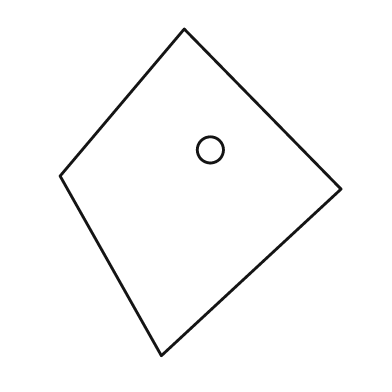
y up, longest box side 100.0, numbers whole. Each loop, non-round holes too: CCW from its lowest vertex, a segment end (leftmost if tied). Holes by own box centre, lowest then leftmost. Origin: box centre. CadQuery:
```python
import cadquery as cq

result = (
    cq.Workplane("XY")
    .moveTo(-12.0, -50.0)
    .lineTo(43.0, 1.0)
    .lineTo(-5.0, 50.0)
    .lineTo(-43.0, 5.0)
    .close()
    .moveTo(3.0, 13.0)
    .circle(4.0)
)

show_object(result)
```